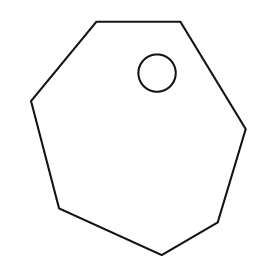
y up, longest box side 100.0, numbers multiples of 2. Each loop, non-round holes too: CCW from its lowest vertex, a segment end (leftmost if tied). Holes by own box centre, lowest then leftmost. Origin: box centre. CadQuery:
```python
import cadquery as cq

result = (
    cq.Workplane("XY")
    .moveTo(10.0, -50.0)
    .lineTo(34.0, -36.0)
    .lineTo(46.0, 4.0)
    .lineTo(18.0, 50.0)
    .lineTo(-18.0, 50.0)
    .lineTo(-46.0, 16.0)
    .lineTo(-34.0, -30.0)
    .close()
    .moveTo(8.0, 28.0)
    .circle(8.0)
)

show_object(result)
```